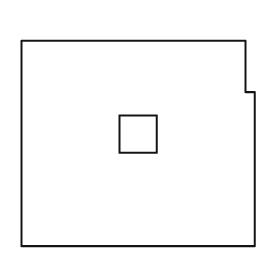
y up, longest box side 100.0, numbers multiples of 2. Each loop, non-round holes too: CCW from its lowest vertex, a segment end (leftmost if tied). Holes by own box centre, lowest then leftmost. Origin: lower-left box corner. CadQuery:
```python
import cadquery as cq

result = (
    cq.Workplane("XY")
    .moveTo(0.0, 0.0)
    .lineTo(100.0, 0.0)
    .lineTo(100.0, 66.0)
    .lineTo(96.0, 66.0)
    .lineTo(96.0, 88.0)
    .lineTo(0.0, 88.0)
    .close()
    .moveTo(42.0, 40.0)
    .lineTo(58.0, 40.0)
    .lineTo(58.0, 56.0)
    .lineTo(42.0, 56.0)
    .close()
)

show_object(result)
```